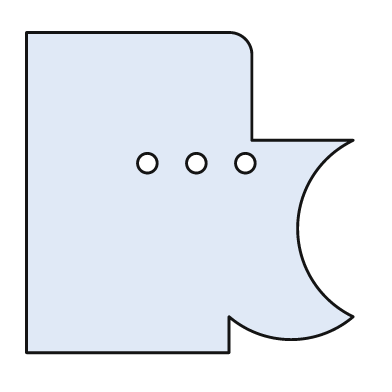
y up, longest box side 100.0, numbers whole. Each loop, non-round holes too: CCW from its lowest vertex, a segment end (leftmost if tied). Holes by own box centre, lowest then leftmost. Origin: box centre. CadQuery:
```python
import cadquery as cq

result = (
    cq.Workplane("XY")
    .moveTo(-50.0, -49.0)
    .lineTo(12.0, -49.0)
    .lineTo(12.0, -38.0)
    .threePointArc((31.0, -45.0), (50.0, -38.0))
    .threePointArc((33.0, -11.0), (50.0, 16.0))
    .lineTo(19.0, 16.0)
    .lineTo(19.0, 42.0)
    .threePointArc((17.0, 47.0), (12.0, 49.0))
    .lineTo(-50.0, 49.0)
    .close()
    .moveTo(-13.0, 9.0)
    .circle(3.0)
    .moveTo(2.0, 9.0)
    .circle(3.0)
    .moveTo(17.0, 9.0)
    .circle(3.0)
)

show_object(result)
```